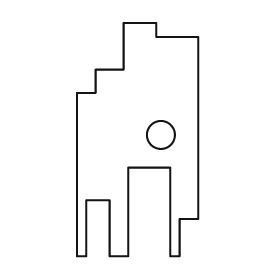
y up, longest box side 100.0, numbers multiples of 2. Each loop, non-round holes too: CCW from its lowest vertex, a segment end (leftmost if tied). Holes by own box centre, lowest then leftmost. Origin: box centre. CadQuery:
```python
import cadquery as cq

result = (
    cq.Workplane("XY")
    .moveTo(-26.0, -50.0)
    .lineTo(-22.0, -50.0)
    .lineTo(-22.0, -26.0)
    .lineTo(-12.0, -26.0)
    .lineTo(-12.0, -50.0)
    .lineTo(-4.0, -50.0)
    .lineTo(-4.0, -12.0)
    .lineTo(14.0, -12.0)
    .lineTo(14.0, -50.0)
    .lineTo(18.0, -50.0)
    .lineTo(18.0, -34.0)
    .lineTo(26.0, -34.0)
    .lineTo(26.0, 44.0)
    .lineTo(8.0, 44.0)
    .lineTo(8.0, 50.0)
    .lineTo(-6.0, 50.0)
    .lineTo(-6.0, 30.0)
    .lineTo(-18.0, 30.0)
    .lineTo(-18.0, 20.0)
    .lineTo(-26.0, 20.0)
    .close()
    .moveTo(10.0, 2.0)
    .circle(6.0)
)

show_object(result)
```